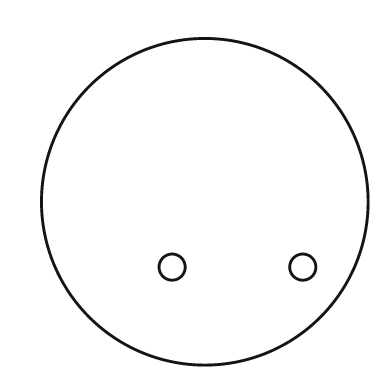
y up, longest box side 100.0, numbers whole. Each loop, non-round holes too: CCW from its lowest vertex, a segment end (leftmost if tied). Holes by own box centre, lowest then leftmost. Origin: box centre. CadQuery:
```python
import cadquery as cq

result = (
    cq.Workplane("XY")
    .moveTo(0.0, 0.0)
    .circle(50.0)
    .moveTo(-10.0, -20.0)
    .circle(4.0)
    .moveTo(30.0, -20.0)
    .circle(4.0)
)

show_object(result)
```